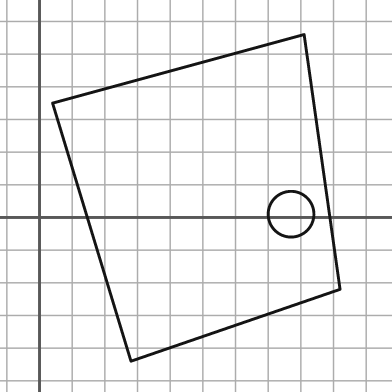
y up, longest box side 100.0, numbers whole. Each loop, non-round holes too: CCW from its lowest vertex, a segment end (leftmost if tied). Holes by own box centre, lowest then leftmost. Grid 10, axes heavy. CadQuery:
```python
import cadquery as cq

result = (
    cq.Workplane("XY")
    .moveTo(28.0, -44.0)
    .lineTo(92.0, -22.0)
    .lineTo(81.0, 56.0)
    .lineTo(4.0, 35.0)
    .close()
    .moveTo(77.0, 1.0)
    .circle(7.0)
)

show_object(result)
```